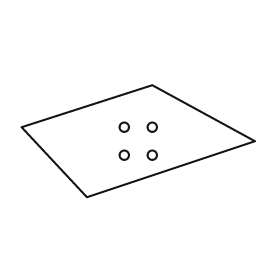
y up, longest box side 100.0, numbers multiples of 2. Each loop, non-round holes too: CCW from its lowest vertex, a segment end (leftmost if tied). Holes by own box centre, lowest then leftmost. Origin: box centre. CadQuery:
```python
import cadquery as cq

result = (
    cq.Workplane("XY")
    .moveTo(-22.0, -24.0)
    .lineTo(50.0, 0.0)
    .lineTo(6.0, 24.0)
    .lineTo(-50.0, 6.0)
    .close()
    .moveTo(-6.0, -6.0)
    .circle(2.0)
    .moveTo(6.0, -6.0)
    .circle(2.0)
    .moveTo(-6.0, 6.0)
    .circle(2.0)
    .moveTo(6.0, 6.0)
    .circle(2.0)
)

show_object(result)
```